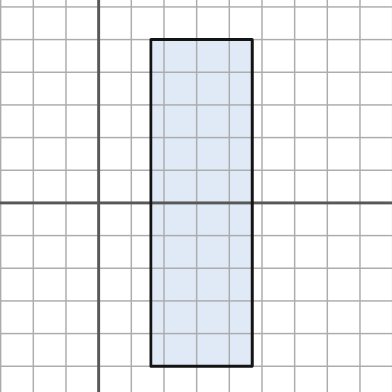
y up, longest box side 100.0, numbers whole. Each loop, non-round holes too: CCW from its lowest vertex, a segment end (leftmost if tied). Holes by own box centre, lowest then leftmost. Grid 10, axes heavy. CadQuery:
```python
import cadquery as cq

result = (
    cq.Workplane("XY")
    .moveTo(16.0, -50.0)
    .lineTo(47.0, -50.0)
    .lineTo(47.0, 50.0)
    .lineTo(16.0, 50.0)
    .close()
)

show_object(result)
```